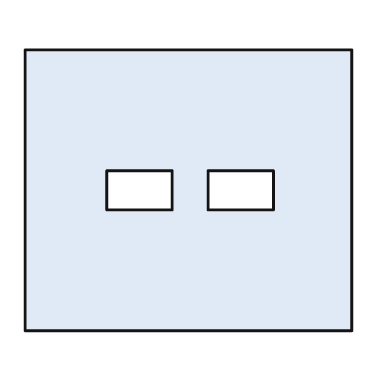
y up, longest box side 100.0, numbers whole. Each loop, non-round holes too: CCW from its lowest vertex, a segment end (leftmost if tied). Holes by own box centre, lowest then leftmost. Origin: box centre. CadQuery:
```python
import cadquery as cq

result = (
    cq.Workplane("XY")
    .moveTo(-50.0, -43.0)
    .lineTo(50.0, -43.0)
    .lineTo(50.0, 43.0)
    .lineTo(-50.0, 43.0)
    .close()
    .moveTo(-25.0, -6.0)
    .lineTo(-5.0, -6.0)
    .lineTo(-5.0, 6.0)
    .lineTo(-25.0, 6.0)
    .close()
    .moveTo(6.0, -6.0)
    .lineTo(26.0, -6.0)
    .lineTo(26.0, 6.0)
    .lineTo(6.0, 6.0)
    .close()
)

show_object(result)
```